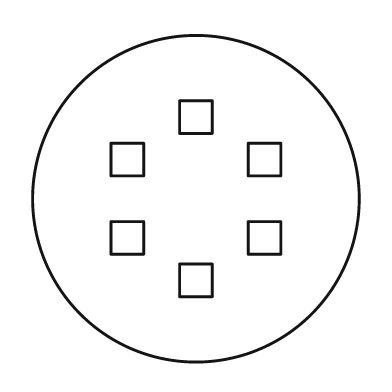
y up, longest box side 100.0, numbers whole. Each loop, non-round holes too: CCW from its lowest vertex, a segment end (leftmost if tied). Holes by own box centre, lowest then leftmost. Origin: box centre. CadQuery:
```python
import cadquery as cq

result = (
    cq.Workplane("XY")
    .moveTo(0.0, 0.0)
    .circle(50.0)
    .moveTo(-5.0, -30.0)
    .lineTo(5.0, -30.0)
    .lineTo(5.0, -20.0)
    .lineTo(-5.0, -20.0)
    .close()
    .moveTo(-26.0, -17.0)
    .lineTo(-16.0, -17.0)
    .lineTo(-16.0, -7.0)
    .lineTo(-26.0, -7.0)
    .close()
    .moveTo(16.0, -17.0)
    .lineTo(26.0, -17.0)
    .lineTo(26.0, -7.0)
    .lineTo(16.0, -7.0)
    .close()
    .moveTo(-26.0, 7.0)
    .lineTo(-16.0, 7.0)
    .lineTo(-16.0, 17.0)
    .lineTo(-26.0, 17.0)
    .close()
    .moveTo(16.0, 7.0)
    .lineTo(26.0, 7.0)
    .lineTo(26.0, 17.0)
    .lineTo(16.0, 17.0)
    .close()
    .moveTo(-5.0, 20.0)
    .lineTo(5.0, 20.0)
    .lineTo(5.0, 30.0)
    .lineTo(-5.0, 30.0)
    .close()
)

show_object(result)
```